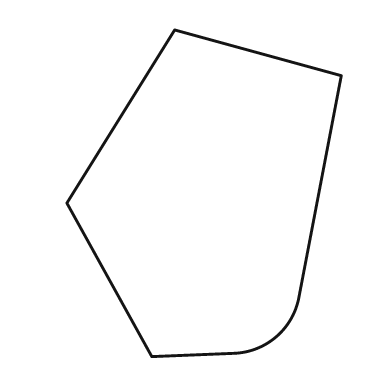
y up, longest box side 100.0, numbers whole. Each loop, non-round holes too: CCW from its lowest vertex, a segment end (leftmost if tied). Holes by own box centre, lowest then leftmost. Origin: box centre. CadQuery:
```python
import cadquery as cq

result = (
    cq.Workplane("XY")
    .moveTo(-16.0, -50.0)
    .lineTo(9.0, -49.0)
    .threePointArc((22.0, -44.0), (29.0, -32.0))
    .lineTo(42.0, 36.0)
    .lineTo(-9.0, 50.0)
    .lineTo(-42.0, -3.0)
    .close()
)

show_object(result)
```